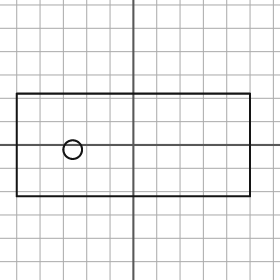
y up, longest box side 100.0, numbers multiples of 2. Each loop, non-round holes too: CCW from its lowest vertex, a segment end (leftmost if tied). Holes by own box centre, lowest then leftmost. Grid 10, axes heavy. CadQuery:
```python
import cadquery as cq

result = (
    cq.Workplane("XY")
    .moveTo(-50.0, -22.0)
    .lineTo(50.0, -22.0)
    .lineTo(50.0, 22.0)
    .lineTo(-50.0, 22.0)
    .close()
    .moveTo(-26.0, -2.0)
    .circle(4.0)
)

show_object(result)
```